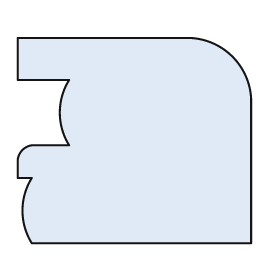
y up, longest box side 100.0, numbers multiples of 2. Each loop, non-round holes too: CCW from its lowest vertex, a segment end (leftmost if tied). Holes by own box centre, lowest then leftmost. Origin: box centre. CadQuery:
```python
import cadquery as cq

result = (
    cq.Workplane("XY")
    .moveTo(-44.0, -44.0)
    .lineTo(50.0, -44.0)
    .lineTo(50.0, 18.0)
    .threePointArc((42.0, 36.0), (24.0, 44.0))
    .lineTo(-50.0, 44.0)
    .lineTo(-50.0, 26.0)
    .lineTo(-28.0, 26.0)
    .threePointArc((-32.0, 12.0), (-28.0, -2.0))
    .lineTo(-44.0, -2.0)
    .threePointArc((-48.0, -4.0), (-50.0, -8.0))
    .lineTo(-50.0, -16.0)
    .lineTo(-44.0, -16.0)
    .threePointArc((-48.0, -30.0), (-44.0, -44.0))
    .close()
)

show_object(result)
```